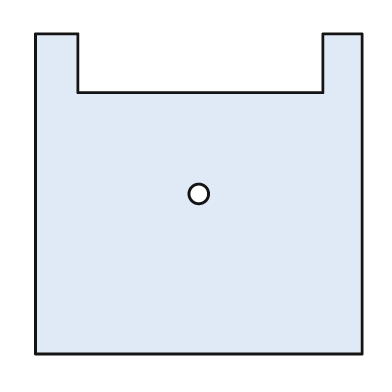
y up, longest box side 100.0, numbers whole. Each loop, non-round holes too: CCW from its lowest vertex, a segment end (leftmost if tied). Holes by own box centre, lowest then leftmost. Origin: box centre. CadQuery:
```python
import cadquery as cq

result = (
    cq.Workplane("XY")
    .moveTo(-50.0, -49.0)
    .lineTo(50.0, -49.0)
    .lineTo(50.0, 49.0)
    .lineTo(38.0, 49.0)
    .lineTo(38.0, 31.0)
    .lineTo(-37.0, 31.0)
    .lineTo(-37.0, 49.0)
    .lineTo(-50.0, 49.0)
    .close()
    .moveTo(0.0, 0.0)
    .circle(3.0)
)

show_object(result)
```